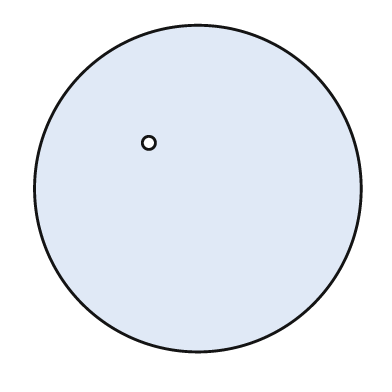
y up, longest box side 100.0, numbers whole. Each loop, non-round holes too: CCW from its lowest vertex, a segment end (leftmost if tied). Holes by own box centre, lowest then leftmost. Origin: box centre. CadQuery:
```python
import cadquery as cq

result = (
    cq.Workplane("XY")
    .moveTo(0.0, 0.0)
    .circle(50.0)
    .moveTo(-15.0, 14.0)
    .circle(2.0)
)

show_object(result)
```